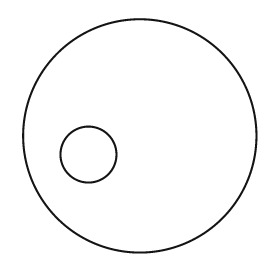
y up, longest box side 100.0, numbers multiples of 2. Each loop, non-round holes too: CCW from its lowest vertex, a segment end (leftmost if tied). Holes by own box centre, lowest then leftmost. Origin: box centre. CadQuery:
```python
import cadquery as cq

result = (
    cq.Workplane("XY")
    .moveTo(0.0, 0.0)
    .circle(50.0)
    .moveTo(-22.0, -8.0)
    .circle(12.0)
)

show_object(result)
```